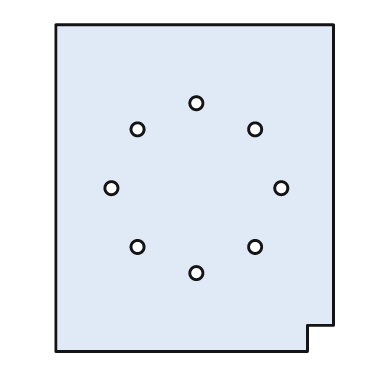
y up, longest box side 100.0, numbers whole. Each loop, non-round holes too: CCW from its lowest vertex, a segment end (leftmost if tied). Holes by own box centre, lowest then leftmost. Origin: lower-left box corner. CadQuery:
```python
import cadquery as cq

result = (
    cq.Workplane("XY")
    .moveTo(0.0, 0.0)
    .lineTo(77.0, 0.0)
    .lineTo(77.0, 8.0)
    .lineTo(85.0, 8.0)
    .lineTo(85.0, 100.0)
    .lineTo(0.0, 100.0)
    .close()
    .moveTo(43.0, 24.0)
    .circle(2.0)
    .moveTo(25.0, 32.0)
    .circle(2.0)
    .moveTo(61.0, 32.0)
    .circle(2.0)
    .moveTo(17.0, 50.0)
    .circle(2.0)
    .moveTo(69.0, 50.0)
    .circle(2.0)
    .moveTo(25.0, 68.0)
    .circle(2.0)
    .moveTo(61.0, 68.0)
    .circle(2.0)
    .moveTo(43.0, 76.0)
    .circle(2.0)
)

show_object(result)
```